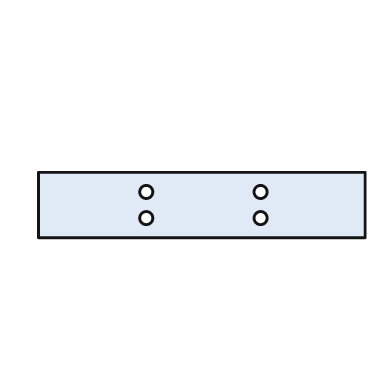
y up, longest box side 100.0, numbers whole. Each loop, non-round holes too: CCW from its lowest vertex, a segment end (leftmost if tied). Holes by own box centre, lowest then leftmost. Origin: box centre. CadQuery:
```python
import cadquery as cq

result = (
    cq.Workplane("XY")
    .moveTo(-50.0, -10.0)
    .lineTo(50.0, -10.0)
    .lineTo(50.0, 10.0)
    .lineTo(-50.0, 10.0)
    .close()
    .moveTo(-17.0, -4.0)
    .circle(2.0)
    .moveTo(18.0, -4.0)
    .circle(2.0)
    .moveTo(-17.0, 4.0)
    .circle(2.0)
    .moveTo(18.0, 4.0)
    .circle(2.0)
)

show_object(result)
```